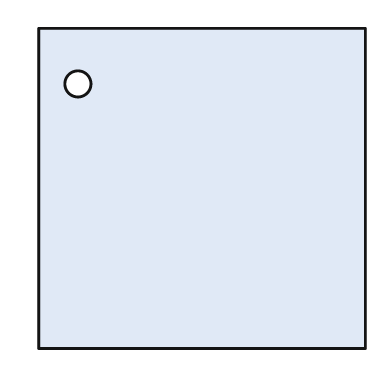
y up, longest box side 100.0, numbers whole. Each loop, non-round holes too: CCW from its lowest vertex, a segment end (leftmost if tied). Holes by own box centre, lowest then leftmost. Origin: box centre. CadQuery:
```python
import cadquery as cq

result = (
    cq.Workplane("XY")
    .moveTo(-50.0, -49.0)
    .lineTo(50.0, -49.0)
    .lineTo(50.0, 49.0)
    .lineTo(-50.0, 49.0)
    .close()
    .moveTo(-38.0, 32.0)
    .circle(4.0)
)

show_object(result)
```